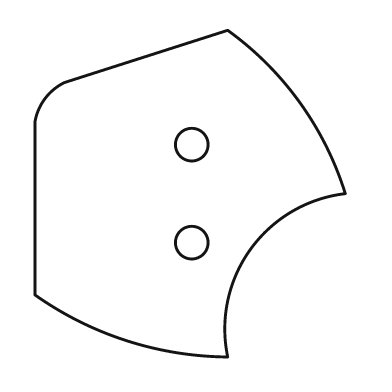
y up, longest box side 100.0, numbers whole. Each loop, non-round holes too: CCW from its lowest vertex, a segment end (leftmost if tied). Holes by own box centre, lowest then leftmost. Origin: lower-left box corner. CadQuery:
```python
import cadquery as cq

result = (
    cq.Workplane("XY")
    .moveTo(59.0, 0.0)
    .threePointArc((66.0, 33.0), (95.0, 50.0))
    .threePointArc((81.0, 78.0), (59.0, 100.0))
    .lineTo(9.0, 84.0)
    .threePointArc((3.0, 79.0), (0.0, 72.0))
    .lineTo(0.0, 19.0)
    .threePointArc((28.0, 5.0), (59.0, 0.0))
    .close()
    .moveTo(48.0, 35.0)
    .circle(5.0)
    .moveTo(48.0, 65.0)
    .circle(5.0)
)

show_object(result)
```